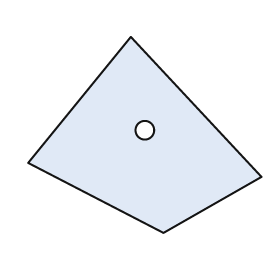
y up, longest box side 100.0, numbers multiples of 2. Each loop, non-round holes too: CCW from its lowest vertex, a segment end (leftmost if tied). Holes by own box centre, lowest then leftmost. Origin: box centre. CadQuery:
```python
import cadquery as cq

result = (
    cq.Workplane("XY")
    .moveTo(8.0, -42.0)
    .lineTo(50.0, -18.0)
    .lineTo(-6.0, 42.0)
    .lineTo(-50.0, -12.0)
    .close()
    .moveTo(0.0, 2.0)
    .circle(4.0)
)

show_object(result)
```